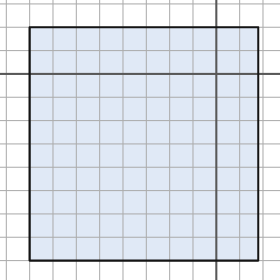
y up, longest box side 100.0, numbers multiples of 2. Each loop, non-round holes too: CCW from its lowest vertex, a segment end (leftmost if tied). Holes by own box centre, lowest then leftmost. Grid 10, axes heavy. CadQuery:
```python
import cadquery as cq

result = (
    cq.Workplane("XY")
    .moveTo(-80.0, -80.0)
    .lineTo(18.0, -80.0)
    .lineTo(18.0, 20.0)
    .lineTo(-80.0, 20.0)
    .close()
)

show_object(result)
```